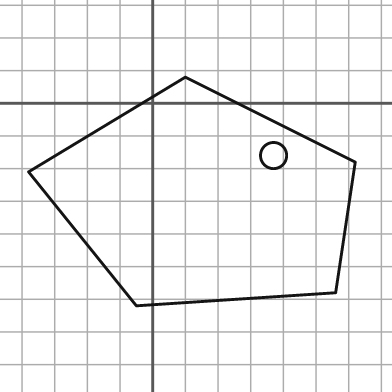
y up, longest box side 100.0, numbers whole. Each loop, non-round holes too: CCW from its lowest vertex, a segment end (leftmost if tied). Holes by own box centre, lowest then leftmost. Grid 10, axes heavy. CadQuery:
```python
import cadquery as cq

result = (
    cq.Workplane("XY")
    .moveTo(-5.0, -62.0)
    .lineTo(56.0, -58.0)
    .lineTo(62.0, -18.0)
    .lineTo(10.0, 8.0)
    .lineTo(-38.0, -21.0)
    .close()
    .moveTo(37.0, -16.0)
    .circle(4.0)
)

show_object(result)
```